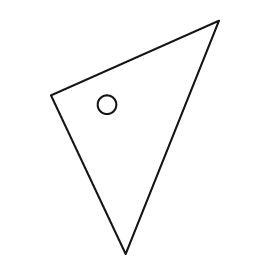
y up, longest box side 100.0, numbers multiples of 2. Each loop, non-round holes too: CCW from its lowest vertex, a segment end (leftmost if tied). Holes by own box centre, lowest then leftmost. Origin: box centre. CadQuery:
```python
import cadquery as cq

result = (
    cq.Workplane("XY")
    .moveTo(-4.0, -50.0)
    .lineTo(36.0, 50.0)
    .lineTo(-36.0, 18.0)
    .close()
    .moveTo(-12.0, 14.0)
    .circle(4.0)
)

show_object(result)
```